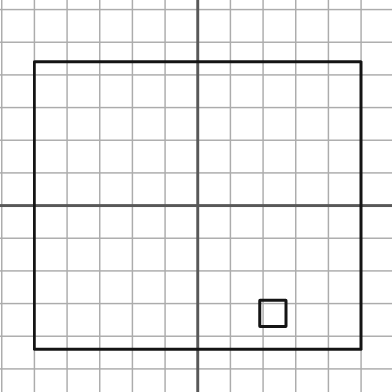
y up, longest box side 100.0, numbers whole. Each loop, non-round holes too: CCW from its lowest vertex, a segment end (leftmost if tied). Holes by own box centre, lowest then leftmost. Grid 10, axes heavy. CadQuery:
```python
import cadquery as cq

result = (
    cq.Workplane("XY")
    .moveTo(-50.0, -44.0)
    .lineTo(50.0, -44.0)
    .lineTo(50.0, 44.0)
    .lineTo(-50.0, 44.0)
    .close()
    .moveTo(19.0, -37.0)
    .lineTo(27.0, -37.0)
    .lineTo(27.0, -29.0)
    .lineTo(19.0, -29.0)
    .close()
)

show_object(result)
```